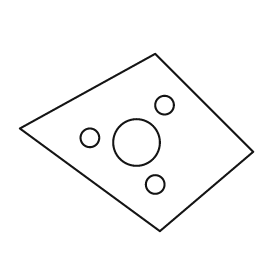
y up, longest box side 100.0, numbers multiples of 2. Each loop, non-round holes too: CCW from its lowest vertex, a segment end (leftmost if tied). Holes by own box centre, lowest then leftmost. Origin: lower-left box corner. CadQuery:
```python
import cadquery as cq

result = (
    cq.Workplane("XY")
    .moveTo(60.0, 0.0)
    .lineTo(100.0, 34.0)
    .lineTo(58.0, 76.0)
    .lineTo(0.0, 44.0)
    .close()
    .moveTo(58.0, 20.0)
    .circle(4.0)
    .moveTo(50.0, 38.0)
    .circle(10.0)
    .moveTo(30.0, 40.0)
    .circle(4.0)
    .moveTo(62.0, 54.0)
    .circle(4.0)
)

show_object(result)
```